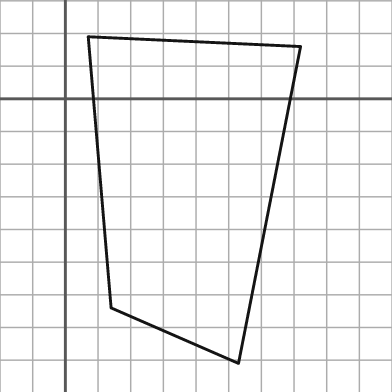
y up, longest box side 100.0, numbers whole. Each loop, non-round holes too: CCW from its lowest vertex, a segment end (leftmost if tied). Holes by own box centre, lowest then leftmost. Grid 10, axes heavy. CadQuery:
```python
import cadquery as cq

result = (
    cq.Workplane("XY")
    .moveTo(53.0, -81.0)
    .lineTo(72.0, 16.0)
    .lineTo(7.0, 19.0)
    .lineTo(14.0, -64.0)
    .close()
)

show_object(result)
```